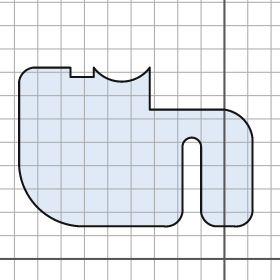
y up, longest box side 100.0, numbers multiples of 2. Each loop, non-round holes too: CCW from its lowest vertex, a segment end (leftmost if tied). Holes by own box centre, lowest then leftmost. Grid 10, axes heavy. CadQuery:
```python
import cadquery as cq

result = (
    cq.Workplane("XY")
    .moveTo(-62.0, 14.0)
    .lineTo(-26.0, 14.0)
    .threePointArc((-20.0, 16.0), (-18.0, 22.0))
    .lineTo(-18.0, 48.0)
    .threePointArc((-14.0, 52.0), (-10.0, 48.0))
    .lineTo(-10.0, 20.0)
    .threePointArc((-8.0, 16.0), (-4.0, 14.0))
    .lineTo(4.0, 14.0)
    .threePointArc((10.0, 16.0), (12.0, 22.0))
    .lineTo(12.0, 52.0)
    .threePointArc((8.0, 60.0), (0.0, 64.0))
    .lineTo(-32.0, 64.0)
    .lineTo(-32.0, 82.0)
    .threePointArc((-44.0, 76.0), (-56.0, 82.0))
    .lineTo(-56.0, 78.0)
    .lineTo(-66.0, 78.0)
    .lineTo(-66.0, 82.0)
    .lineTo(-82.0, 82.0)
    .threePointArc((-86.0, 80.0), (-88.0, 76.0))
    .lineTo(-88.0, 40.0)
    .threePointArc((-80.0, 22.0), (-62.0, 14.0))
    .close()
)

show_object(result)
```